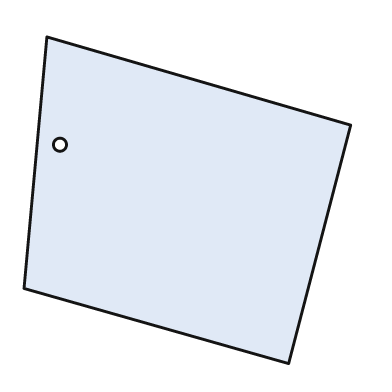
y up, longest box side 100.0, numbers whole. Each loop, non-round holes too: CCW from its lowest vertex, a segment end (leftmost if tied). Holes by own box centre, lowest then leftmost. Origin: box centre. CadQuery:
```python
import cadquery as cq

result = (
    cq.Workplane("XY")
    .moveTo(31.0, -50.0)
    .lineTo(50.0, 23.0)
    .lineTo(-43.0, 50.0)
    .lineTo(-50.0, -27.0)
    .close()
    .moveTo(-39.0, 17.0)
    .circle(2.0)
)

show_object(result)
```